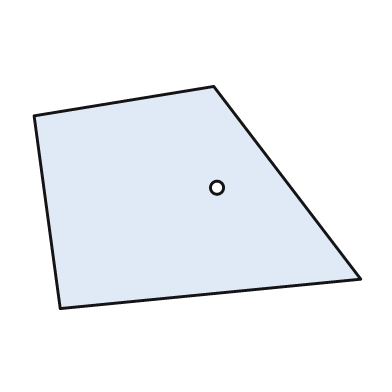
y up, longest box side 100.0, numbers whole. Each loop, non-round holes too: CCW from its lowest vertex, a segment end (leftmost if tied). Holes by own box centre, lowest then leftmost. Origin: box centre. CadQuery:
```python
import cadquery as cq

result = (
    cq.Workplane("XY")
    .moveTo(-42.0, -34.0)
    .lineTo(50.0, -25.0)
    .lineTo(5.0, 34.0)
    .lineTo(-50.0, 25.0)
    .close()
    .moveTo(6.0, 3.0)
    .circle(2.0)
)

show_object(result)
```